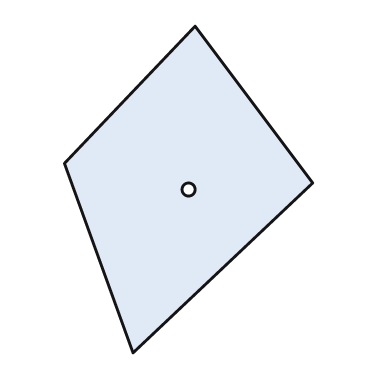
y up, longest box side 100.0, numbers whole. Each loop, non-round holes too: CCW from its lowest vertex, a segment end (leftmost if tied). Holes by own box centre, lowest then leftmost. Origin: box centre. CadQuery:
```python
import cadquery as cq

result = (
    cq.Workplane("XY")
    .moveTo(-17.0, -50.0)
    .lineTo(38.0, 2.0)
    .lineTo(2.0, 50.0)
    .lineTo(-38.0, 8.0)
    .close()
    .moveTo(0.0, 0.0)
    .circle(2.0)
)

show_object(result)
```